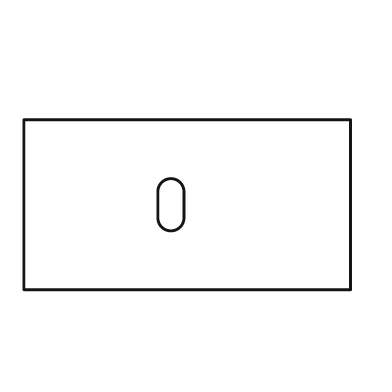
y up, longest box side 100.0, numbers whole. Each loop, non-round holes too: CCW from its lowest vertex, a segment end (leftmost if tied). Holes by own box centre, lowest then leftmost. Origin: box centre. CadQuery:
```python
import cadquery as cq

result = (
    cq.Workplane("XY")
    .moveTo(-50.0, -26.0)
    .lineTo(50.0, -26.0)
    .lineTo(50.0, 26.0)
    .lineTo(-50.0, 26.0)
    .close()
    .moveTo(-9.0, -4.0)
    .threePointArc((-5.0, -8.0), (-1.0, -4.0))
    .lineTo(-1.0, 4.0)
    .threePointArc((-5.0, 8.0), (-9.0, 4.0))
    .close()
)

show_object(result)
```